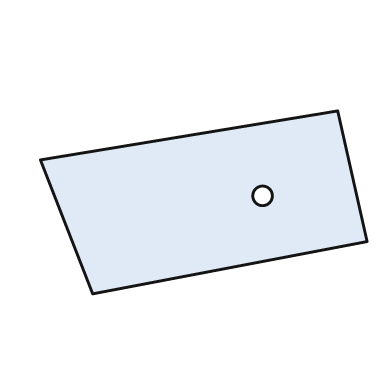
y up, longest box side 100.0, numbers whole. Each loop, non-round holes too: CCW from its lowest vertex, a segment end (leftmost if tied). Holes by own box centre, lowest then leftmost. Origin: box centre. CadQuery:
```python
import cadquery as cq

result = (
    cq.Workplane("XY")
    .moveTo(-34.0, -28.0)
    .lineTo(50.0, -12.0)
    .lineTo(41.0, 28.0)
    .lineTo(-50.0, 13.0)
    .close()
    .moveTo(18.0, 2.0)
    .circle(3.0)
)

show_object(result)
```